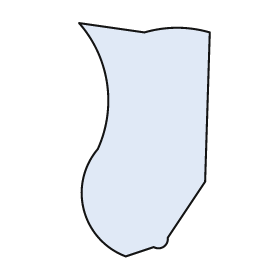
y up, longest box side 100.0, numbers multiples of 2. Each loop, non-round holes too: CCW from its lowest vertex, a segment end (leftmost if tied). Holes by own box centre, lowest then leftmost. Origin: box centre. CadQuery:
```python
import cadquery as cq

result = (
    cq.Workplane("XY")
    .moveTo(-8.0, -50.0)
    .lineTo(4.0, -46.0)
    .threePointArc((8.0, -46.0), (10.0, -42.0))
    .lineTo(26.0, -18.0)
    .lineTo(28.0, 46.0)
    .threePointArc((14.0, 48.0), (0.0, 46.0))
    .lineTo(-28.0, 50.0)
    .threePointArc((-16.0, 24.0), (-20.0, -4.0))
    .threePointArc((-26.0, -30.0), (-8.0, -50.0))
    .close()
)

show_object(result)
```